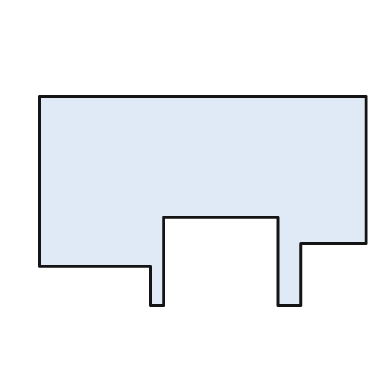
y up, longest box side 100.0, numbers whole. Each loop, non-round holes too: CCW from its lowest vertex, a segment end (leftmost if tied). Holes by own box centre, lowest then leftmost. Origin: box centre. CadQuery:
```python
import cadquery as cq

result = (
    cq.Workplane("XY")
    .moveTo(-16.0, -32.0)
    .lineTo(-12.0, -32.0)
    .lineTo(-12.0, -5.0)
    .lineTo(23.0, -5.0)
    .lineTo(23.0, -32.0)
    .lineTo(30.0, -32.0)
    .lineTo(30.0, -13.0)
    .lineTo(50.0, -13.0)
    .lineTo(50.0, 32.0)
    .lineTo(-50.0, 32.0)
    .lineTo(-50.0, -20.0)
    .lineTo(-16.0, -20.0)
    .close()
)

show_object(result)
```